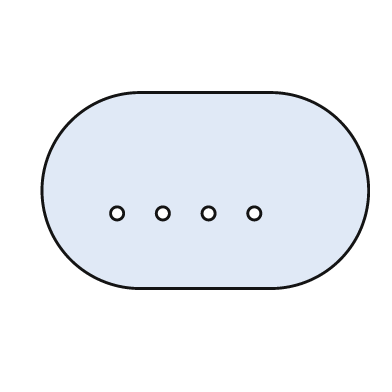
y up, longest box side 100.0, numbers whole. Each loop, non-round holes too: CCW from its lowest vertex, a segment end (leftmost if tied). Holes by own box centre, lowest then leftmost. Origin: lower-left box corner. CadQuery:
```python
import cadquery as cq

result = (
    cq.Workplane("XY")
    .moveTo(30.0, 0.0)
    .lineTo(70.0, 0.0)
    .threePointArc((100.0, 30.0), (70.0, 60.0))
    .lineTo(30.0, 60.0)
    .threePointArc((0.0, 30.0), (30.0, 0.0))
    .close()
    .moveTo(23.0, 23.0)
    .circle(2.0)
    .moveTo(37.0, 23.0)
    .circle(2.0)
    .moveTo(51.0, 23.0)
    .circle(2.0)
    .moveTo(65.0, 23.0)
    .circle(2.0)
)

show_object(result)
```